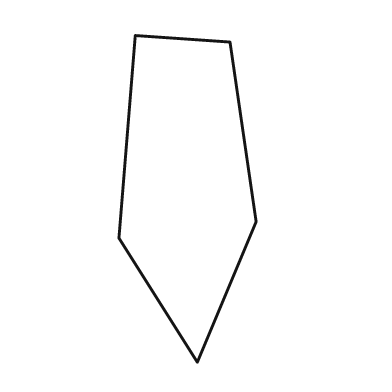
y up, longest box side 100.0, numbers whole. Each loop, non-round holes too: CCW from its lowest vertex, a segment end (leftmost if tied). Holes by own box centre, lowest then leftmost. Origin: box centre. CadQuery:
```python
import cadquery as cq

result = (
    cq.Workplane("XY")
    .moveTo(3.0, -50.0)
    .lineTo(21.0, -7.0)
    .lineTo(13.0, 48.0)
    .lineTo(-16.0, 50.0)
    .lineTo(-21.0, -12.0)
    .close()
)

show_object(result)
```